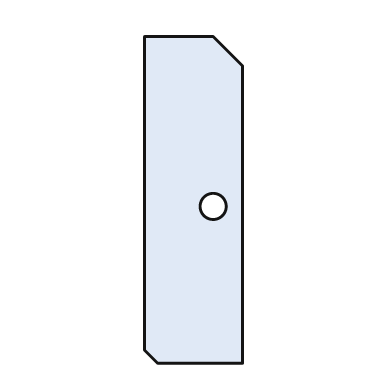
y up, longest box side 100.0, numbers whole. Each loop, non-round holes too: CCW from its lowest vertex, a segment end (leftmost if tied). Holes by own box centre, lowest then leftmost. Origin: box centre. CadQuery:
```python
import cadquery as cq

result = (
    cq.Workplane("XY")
    .moveTo(-11.0, -50.0)
    .lineTo(15.0, -50.0)
    .lineTo(15.0, 41.0)
    .lineTo(6.0, 50.0)
    .lineTo(-15.0, 50.0)
    .lineTo(-15.0, -46.0)
    .close()
    .moveTo(6.0, -2.0)
    .circle(4.0)
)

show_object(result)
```